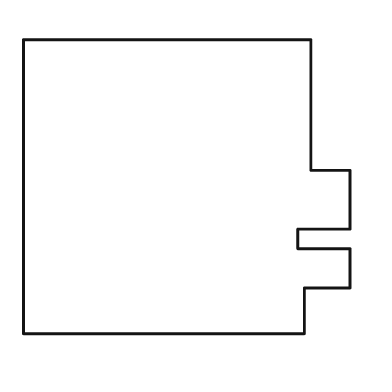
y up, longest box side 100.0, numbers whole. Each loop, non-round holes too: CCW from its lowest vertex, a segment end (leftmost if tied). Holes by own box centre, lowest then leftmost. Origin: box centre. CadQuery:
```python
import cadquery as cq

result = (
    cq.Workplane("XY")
    .moveTo(-50.0, -45.0)
    .lineTo(36.0, -45.0)
    .lineTo(36.0, -31.0)
    .lineTo(50.0, -31.0)
    .lineTo(50.0, -19.0)
    .lineTo(34.0, -19.0)
    .lineTo(34.0, -13.0)
    .lineTo(50.0, -13.0)
    .lineTo(50.0, 5.0)
    .lineTo(38.0, 5.0)
    .lineTo(38.0, 45.0)
    .lineTo(-50.0, 45.0)
    .close()
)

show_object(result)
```